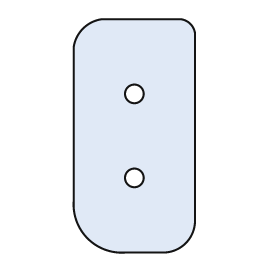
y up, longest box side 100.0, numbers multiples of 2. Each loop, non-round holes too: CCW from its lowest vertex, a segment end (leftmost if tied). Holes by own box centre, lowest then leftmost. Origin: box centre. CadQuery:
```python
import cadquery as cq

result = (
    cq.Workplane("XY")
    .moveTo(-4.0, -50.0)
    .lineTo(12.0, -50.0)
    .threePointArc((22.0, -46.0), (26.0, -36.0))
    .lineTo(26.0, 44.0)
    .threePointArc((24.0, 48.0), (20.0, 50.0))
    .lineTo(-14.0, 50.0)
    .threePointArc((-22.0, 46.0), (-26.0, 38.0))
    .lineTo(-26.0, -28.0)
    .threePointArc((-20.0, -44.0), (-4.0, -50.0))
    .close()
    .moveTo(0.0, -18.0)
    .circle(4.0)
    .moveTo(0.0, 18.0)
    .circle(4.0)
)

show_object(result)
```